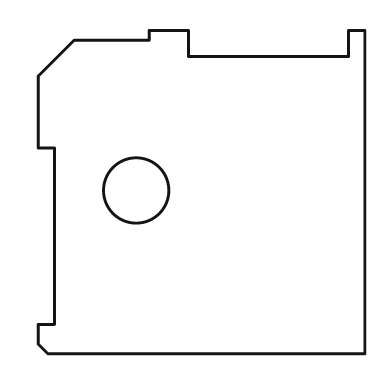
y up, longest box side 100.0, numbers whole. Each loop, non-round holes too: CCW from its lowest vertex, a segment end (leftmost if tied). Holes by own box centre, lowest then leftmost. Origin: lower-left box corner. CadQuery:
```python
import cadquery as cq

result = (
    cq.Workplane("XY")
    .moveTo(3.0, 0.0)
    .lineTo(100.0, 0.0)
    .lineTo(100.0, 99.0)
    .lineTo(95.0, 99.0)
    .lineTo(95.0, 91.0)
    .lineTo(46.0, 91.0)
    .lineTo(46.0, 99.0)
    .lineTo(34.0, 99.0)
    .lineTo(34.0, 96.0)
    .lineTo(11.0, 96.0)
    .lineTo(0.0, 85.0)
    .lineTo(0.0, 63.0)
    .lineTo(5.0, 63.0)
    .lineTo(5.0, 9.0)
    .lineTo(0.0, 9.0)
    .lineTo(0.0, 3.0)
    .close()
    .moveTo(30.0, 50.0)
    .circle(10.0)
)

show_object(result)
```